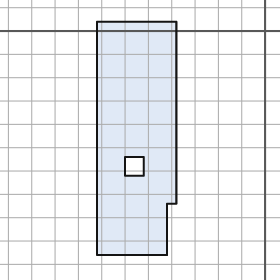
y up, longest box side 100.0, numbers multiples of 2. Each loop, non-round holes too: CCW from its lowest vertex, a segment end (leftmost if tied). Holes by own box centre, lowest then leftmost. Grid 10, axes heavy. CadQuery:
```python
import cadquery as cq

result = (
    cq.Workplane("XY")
    .moveTo(-72.0, -96.0)
    .lineTo(-42.0, -96.0)
    .lineTo(-42.0, -74.0)
    .lineTo(-38.0, -74.0)
    .lineTo(-38.0, 4.0)
    .lineTo(-72.0, 4.0)
    .close()
    .moveTo(-60.0, -62.0)
    .lineTo(-52.0, -62.0)
    .lineTo(-52.0, -54.0)
    .lineTo(-60.0, -54.0)
    .close()
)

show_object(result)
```